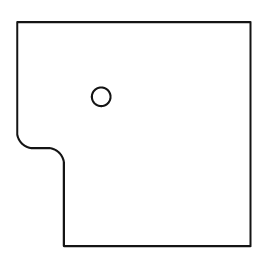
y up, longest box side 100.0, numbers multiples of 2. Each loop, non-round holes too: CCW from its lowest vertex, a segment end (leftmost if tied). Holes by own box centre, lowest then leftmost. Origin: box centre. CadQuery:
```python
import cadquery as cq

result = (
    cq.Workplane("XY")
    .moveTo(-30.0, -48.0)
    .lineTo(50.0, -48.0)
    .lineTo(50.0, 48.0)
    .lineTo(-50.0, 48.0)
    .lineTo(-50.0, 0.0)
    .threePointArc((-48.0, -4.0), (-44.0, -6.0))
    .lineTo(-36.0, -6.0)
    .threePointArc((-32.0, -8.0), (-30.0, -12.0))
    .close()
    .moveTo(-14.0, 16.0)
    .circle(4.0)
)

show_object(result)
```